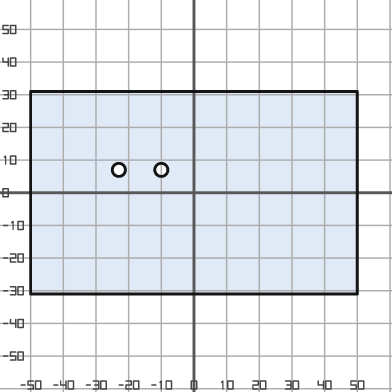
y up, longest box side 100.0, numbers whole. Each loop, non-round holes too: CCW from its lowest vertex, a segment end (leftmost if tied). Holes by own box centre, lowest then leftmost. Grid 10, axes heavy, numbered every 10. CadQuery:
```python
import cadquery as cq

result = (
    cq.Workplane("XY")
    .moveTo(-50.0, -31.0)
    .lineTo(50.0, -31.0)
    .lineTo(50.0, 31.0)
    .lineTo(-50.0, 31.0)
    .close()
    .moveTo(-23.0, 7.0)
    .circle(2.0)
    .moveTo(-10.0, 7.0)
    .circle(2.0)
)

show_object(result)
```